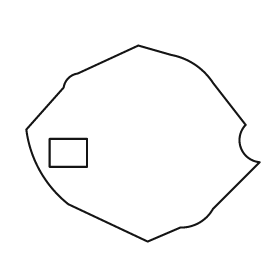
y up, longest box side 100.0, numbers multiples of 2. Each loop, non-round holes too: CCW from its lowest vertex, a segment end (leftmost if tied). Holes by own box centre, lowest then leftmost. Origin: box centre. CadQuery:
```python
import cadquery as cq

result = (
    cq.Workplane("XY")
    .moveTo(2.0, -42.0)
    .lineTo(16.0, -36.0)
    .threePointArc((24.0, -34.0), (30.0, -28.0))
    .lineTo(50.0, -8.0)
    .threePointArc((42.0, -2.0), (44.0, 8.0))
    .lineTo(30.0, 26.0)
    .threePointArc((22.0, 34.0), (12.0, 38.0))
    .lineTo(-2.0, 42.0)
    .lineTo(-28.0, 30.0)
    .threePointArc((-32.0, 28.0), (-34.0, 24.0))
    .lineTo(-50.0, 6.0)
    .threePointArc((-44.0, -12.0), (-32.0, -26.0))
    .close()
    .moveTo(-40.0, -10.0)
    .lineTo(-24.0, -10.0)
    .lineTo(-24.0, 2.0)
    .lineTo(-40.0, 2.0)
    .close()
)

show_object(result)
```